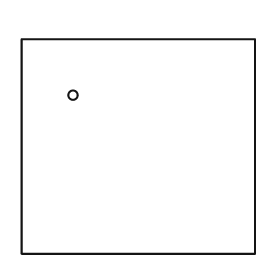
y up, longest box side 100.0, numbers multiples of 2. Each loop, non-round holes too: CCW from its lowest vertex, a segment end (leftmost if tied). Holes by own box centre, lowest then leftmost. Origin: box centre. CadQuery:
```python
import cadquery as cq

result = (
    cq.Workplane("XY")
    .moveTo(-50.0, -46.0)
    .lineTo(50.0, -46.0)
    .lineTo(50.0, 46.0)
    .lineTo(-50.0, 46.0)
    .close()
    .moveTo(-28.0, 22.0)
    .circle(2.0)
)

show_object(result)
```